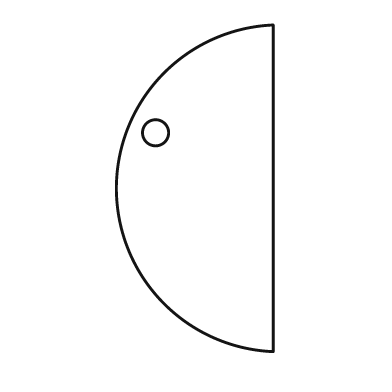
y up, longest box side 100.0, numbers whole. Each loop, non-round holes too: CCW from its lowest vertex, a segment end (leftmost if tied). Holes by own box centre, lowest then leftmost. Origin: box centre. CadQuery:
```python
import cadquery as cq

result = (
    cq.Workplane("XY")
    .moveTo(24.0, -50.0)
    .lineTo(24.0, 50.0)
    .threePointArc((-24.0, 0.0), (24.0, -50.0))
    .close()
    .moveTo(-12.0, 17.0)
    .circle(4.0)
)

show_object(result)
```